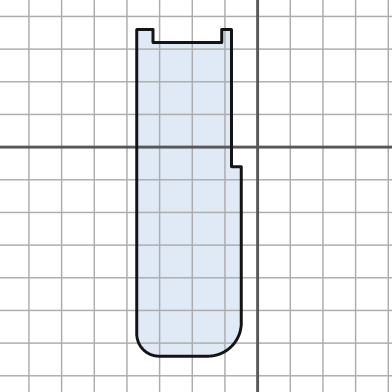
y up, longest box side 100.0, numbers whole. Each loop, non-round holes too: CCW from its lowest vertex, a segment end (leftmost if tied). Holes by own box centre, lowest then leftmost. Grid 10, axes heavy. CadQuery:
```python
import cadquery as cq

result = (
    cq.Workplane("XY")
    .moveTo(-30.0, -64.0)
    .lineTo(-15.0, -64.0)
    .threePointArc((-8.0, -61.0), (-5.0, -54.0))
    .lineTo(-5.0, -6.0)
    .lineTo(-8.0, -6.0)
    .lineTo(-8.0, 36.0)
    .lineTo(-11.0, 36.0)
    .lineTo(-11.0, 32.0)
    .lineTo(-32.0, 32.0)
    .lineTo(-32.0, 36.0)
    .lineTo(-37.0, 36.0)
    .lineTo(-37.0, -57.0)
    .threePointArc((-35.0, -62.0), (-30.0, -64.0))
    .close()
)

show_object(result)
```